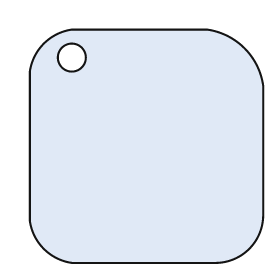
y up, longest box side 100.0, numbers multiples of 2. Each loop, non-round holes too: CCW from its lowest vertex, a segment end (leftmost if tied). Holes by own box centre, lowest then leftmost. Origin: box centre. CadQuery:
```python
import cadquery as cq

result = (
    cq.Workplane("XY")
    .moveTo(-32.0, -50.0)
    .lineTo(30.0, -50.0)
    .threePointArc((44.0, -44.0), (50.0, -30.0))
    .lineTo(50.0, 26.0)
    .threePointArc((42.0, 42.0), (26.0, 50.0))
    .lineTo(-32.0, 50.0)
    .threePointArc((-44.0, 44.0), (-50.0, 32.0))
    .lineTo(-50.0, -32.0)
    .threePointArc((-44.0, -44.0), (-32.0, -50.0))
    .close()
    .moveTo(-32.0, 38.0)
    .circle(6.0)
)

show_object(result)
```